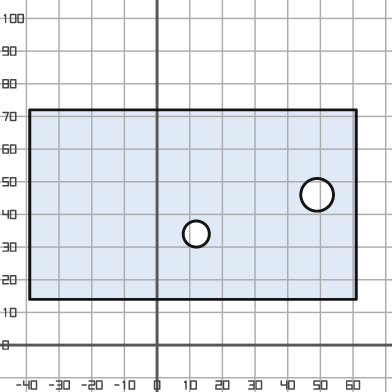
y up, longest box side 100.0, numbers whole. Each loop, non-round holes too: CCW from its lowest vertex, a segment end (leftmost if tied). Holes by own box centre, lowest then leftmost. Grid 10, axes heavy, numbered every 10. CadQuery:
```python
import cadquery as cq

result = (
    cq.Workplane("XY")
    .moveTo(-39.0, 14.0)
    .lineTo(61.0, 14.0)
    .lineTo(61.0, 72.0)
    .lineTo(-39.0, 72.0)
    .close()
    .moveTo(12.0, 34.0)
    .circle(4.0)
    .moveTo(49.0, 46.0)
    .circle(5.0)
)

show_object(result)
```